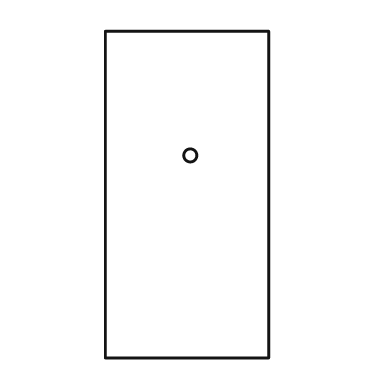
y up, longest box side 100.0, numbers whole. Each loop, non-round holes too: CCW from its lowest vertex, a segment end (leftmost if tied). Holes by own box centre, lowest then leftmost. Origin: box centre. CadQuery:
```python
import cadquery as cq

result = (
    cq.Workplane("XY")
    .moveTo(-25.0, -50.0)
    .lineTo(25.0, -50.0)
    .lineTo(25.0, 50.0)
    .lineTo(-25.0, 50.0)
    .close()
    .moveTo(1.0, 12.0)
    .circle(2.0)
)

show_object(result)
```